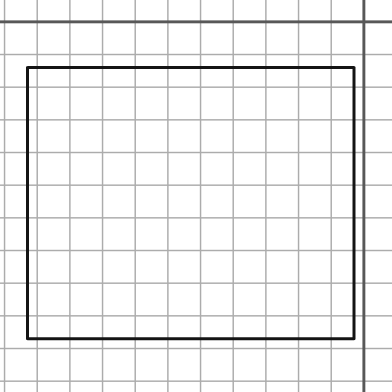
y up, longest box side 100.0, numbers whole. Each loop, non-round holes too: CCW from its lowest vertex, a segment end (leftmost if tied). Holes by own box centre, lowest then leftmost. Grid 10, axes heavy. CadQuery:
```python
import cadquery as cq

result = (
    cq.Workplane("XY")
    .moveTo(-103.0, -97.0)
    .lineTo(-3.0, -97.0)
    .lineTo(-3.0, -14.0)
    .lineTo(-103.0, -14.0)
    .close()
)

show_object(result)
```